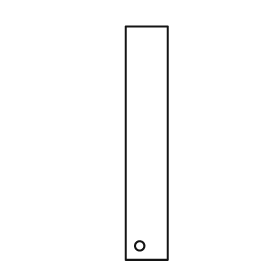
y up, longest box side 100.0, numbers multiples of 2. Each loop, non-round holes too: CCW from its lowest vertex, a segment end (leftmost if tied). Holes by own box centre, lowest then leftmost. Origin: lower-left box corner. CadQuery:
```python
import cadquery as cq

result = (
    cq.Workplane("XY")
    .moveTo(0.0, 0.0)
    .lineTo(18.0, 0.0)
    .lineTo(18.0, 100.0)
    .lineTo(0.0, 100.0)
    .close()
    .moveTo(6.0, 6.0)
    .circle(2.0)
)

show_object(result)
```